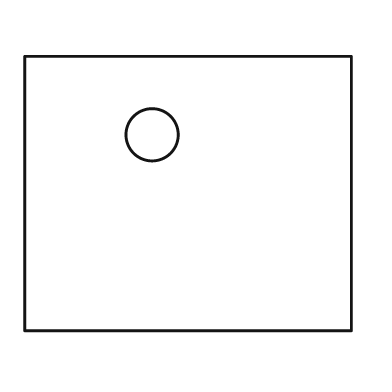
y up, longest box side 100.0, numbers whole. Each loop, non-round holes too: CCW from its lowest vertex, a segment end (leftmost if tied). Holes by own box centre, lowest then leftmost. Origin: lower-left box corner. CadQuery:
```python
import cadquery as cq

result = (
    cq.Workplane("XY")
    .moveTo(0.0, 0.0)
    .lineTo(100.0, 0.0)
    .lineTo(100.0, 84.0)
    .lineTo(0.0, 84.0)
    .close()
    .moveTo(39.0, 60.0)
    .circle(8.0)
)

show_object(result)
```